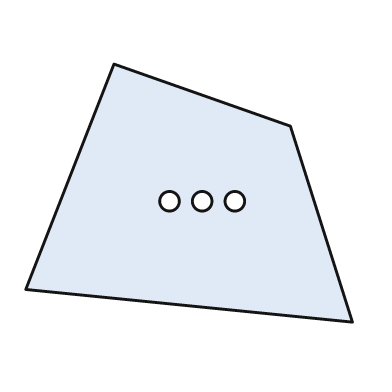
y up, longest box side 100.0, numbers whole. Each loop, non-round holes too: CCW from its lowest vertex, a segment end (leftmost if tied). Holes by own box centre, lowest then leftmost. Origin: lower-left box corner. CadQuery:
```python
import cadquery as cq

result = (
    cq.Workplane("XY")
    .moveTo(100.0, 0.0)
    .lineTo(81.0, 60.0)
    .lineTo(27.0, 79.0)
    .lineTo(0.0, 10.0)
    .close()
    .moveTo(44.0, 37.0)
    .circle(3.0)
    .moveTo(54.0, 37.0)
    .circle(3.0)
    .moveTo(64.0, 37.0)
    .circle(3.0)
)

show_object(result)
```